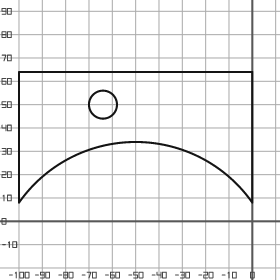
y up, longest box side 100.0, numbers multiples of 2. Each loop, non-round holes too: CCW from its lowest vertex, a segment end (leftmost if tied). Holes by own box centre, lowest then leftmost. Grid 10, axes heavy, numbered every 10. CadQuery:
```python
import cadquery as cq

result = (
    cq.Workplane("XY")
    .moveTo(-100.0, 8.0)
    .threePointArc((-50.0, 34.0), (0.0, 8.0))
    .lineTo(0.0, 64.0)
    .lineTo(-100.0, 64.0)
    .close()
    .moveTo(-64.0, 50.0)
    .circle(6.0)
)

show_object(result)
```